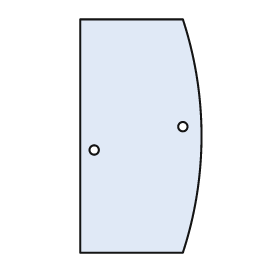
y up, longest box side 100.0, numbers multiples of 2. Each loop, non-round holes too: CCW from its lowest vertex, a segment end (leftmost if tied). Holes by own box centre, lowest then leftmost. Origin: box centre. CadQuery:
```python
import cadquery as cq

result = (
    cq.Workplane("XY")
    .moveTo(-26.0, -50.0)
    .lineTo(18.0, -50.0)
    .threePointArc((26.0, 0.0), (18.0, 50.0))
    .lineTo(-26.0, 50.0)
    .close()
    .moveTo(-20.0, -6.0)
    .circle(2.0)
    .moveTo(18.0, 4.0)
    .circle(2.0)
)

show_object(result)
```